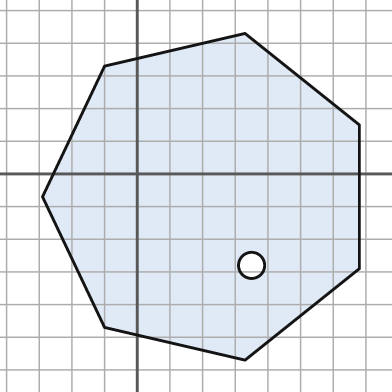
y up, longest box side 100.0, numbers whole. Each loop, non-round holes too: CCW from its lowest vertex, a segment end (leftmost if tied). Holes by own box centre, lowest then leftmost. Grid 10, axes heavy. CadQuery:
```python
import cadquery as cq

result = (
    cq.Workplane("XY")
    .moveTo(33.0, -57.0)
    .lineTo(68.0, -29.0)
    .lineTo(68.0, 15.0)
    .lineTo(33.0, 43.0)
    .lineTo(-10.0, 33.0)
    .lineTo(-29.0, -7.0)
    .lineTo(-10.0, -47.0)
    .close()
    .moveTo(35.0, -28.0)
    .circle(4.0)
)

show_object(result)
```